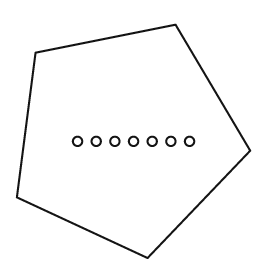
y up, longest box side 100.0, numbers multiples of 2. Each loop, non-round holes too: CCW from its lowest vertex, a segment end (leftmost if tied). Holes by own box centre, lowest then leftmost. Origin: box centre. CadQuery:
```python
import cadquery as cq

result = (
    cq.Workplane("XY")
    .moveTo(6.0, -50.0)
    .lineTo(50.0, -4.0)
    .lineTo(18.0, 50.0)
    .lineTo(-42.0, 38.0)
    .lineTo(-50.0, -24.0)
    .close()
    .moveTo(-24.0, 0.0)
    .circle(2.0)
    .moveTo(-16.0, 0.0)
    .circle(2.0)
    .moveTo(-8.0, 0.0)
    .circle(2.0)
    .moveTo(0.0, 0.0)
    .circle(2.0)
    .moveTo(8.0, 0.0)
    .circle(2.0)
    .moveTo(16.0, 0.0)
    .circle(2.0)
    .moveTo(24.0, 0.0)
    .circle(2.0)
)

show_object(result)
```